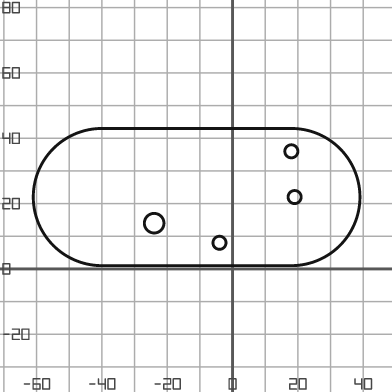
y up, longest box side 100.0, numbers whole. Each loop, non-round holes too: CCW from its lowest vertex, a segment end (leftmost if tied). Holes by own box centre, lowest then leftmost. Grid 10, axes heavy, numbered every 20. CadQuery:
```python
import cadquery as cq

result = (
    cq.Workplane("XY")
    .moveTo(-40.0, 1.0)
    .lineTo(18.0, 1.0)
    .threePointArc((39.0, 22.0), (18.0, 43.0))
    .lineTo(-40.0, 43.0)
    .threePointArc((-61.0, 22.0), (-40.0, 1.0))
    .close()
    .moveTo(-4.0, 8.0)
    .circle(2.0)
    .moveTo(-24.0, 14.0)
    .circle(3.0)
    .moveTo(19.0, 22.0)
    .circle(2.0)
    .moveTo(18.0, 36.0)
    .circle(2.0)
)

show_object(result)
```